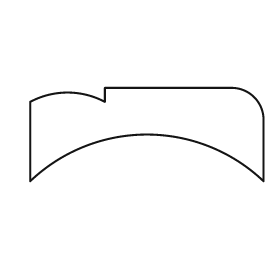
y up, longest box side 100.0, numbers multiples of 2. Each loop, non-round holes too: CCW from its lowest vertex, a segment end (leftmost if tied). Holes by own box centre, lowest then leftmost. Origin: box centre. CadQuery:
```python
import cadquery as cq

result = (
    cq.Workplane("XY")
    .moveTo(-50.0, -20.0)
    .threePointArc((0.0, 0.0), (50.0, -20.0))
    .lineTo(50.0, 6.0)
    .threePointArc((46.0, 16.0), (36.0, 20.0))
    .lineTo(-18.0, 20.0)
    .lineTo(-18.0, 14.0)
    .threePointArc((-34.0, 18.0), (-50.0, 14.0))
    .close()
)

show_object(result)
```